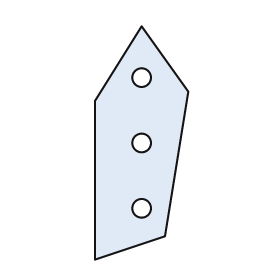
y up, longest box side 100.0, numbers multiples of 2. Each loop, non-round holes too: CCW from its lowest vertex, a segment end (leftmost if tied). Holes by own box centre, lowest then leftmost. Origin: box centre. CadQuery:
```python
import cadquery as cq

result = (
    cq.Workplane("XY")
    .moveTo(-20.0, -50.0)
    .lineTo(10.0, -40.0)
    .lineTo(20.0, 22.0)
    .lineTo(0.0, 50.0)
    .lineTo(-20.0, 18.0)
    .close()
    .moveTo(0.0, -28.0)
    .circle(4.0)
    .moveTo(0.0, 0.0)
    .circle(4.0)
    .moveTo(0.0, 28.0)
    .circle(4.0)
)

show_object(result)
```